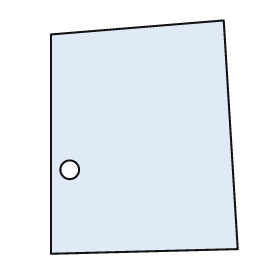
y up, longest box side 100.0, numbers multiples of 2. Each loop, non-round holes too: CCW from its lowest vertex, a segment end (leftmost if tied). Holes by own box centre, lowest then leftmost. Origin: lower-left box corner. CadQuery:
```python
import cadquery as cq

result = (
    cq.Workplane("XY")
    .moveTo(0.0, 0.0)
    .lineTo(80.0, 2.0)
    .lineTo(74.0, 100.0)
    .lineTo(0.0, 94.0)
    .close()
    .moveTo(8.0, 36.0)
    .circle(4.0)
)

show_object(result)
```